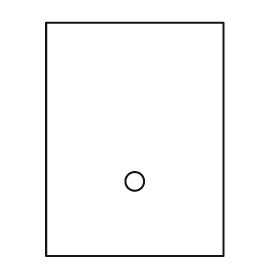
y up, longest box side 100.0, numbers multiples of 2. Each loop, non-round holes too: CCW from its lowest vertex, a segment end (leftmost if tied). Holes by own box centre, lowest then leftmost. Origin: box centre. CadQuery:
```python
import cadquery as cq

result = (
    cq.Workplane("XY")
    .moveTo(-38.0, -50.0)
    .lineTo(38.0, -50.0)
    .lineTo(38.0, 50.0)
    .lineTo(-38.0, 50.0)
    .close()
    .moveTo(0.0, -18.0)
    .circle(4.0)
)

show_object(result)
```